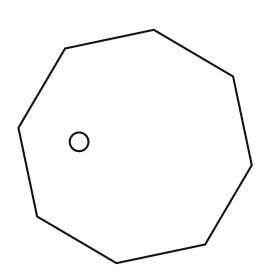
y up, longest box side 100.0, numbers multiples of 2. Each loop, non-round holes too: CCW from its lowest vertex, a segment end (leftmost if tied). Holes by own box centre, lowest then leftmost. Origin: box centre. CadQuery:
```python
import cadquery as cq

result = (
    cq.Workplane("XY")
    .moveTo(-8.0, -50.0)
    .lineTo(30.0, -42.0)
    .lineTo(50.0, -8.0)
    .lineTo(42.0, 30.0)
    .lineTo(8.0, 50.0)
    .lineTo(-30.0, 42.0)
    .lineTo(-50.0, 8.0)
    .lineTo(-42.0, -30.0)
    .close()
    .moveTo(-24.0, 2.0)
    .circle(4.0)
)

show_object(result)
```